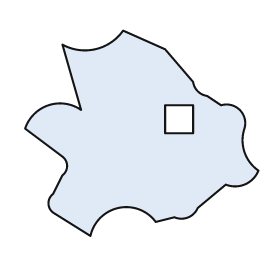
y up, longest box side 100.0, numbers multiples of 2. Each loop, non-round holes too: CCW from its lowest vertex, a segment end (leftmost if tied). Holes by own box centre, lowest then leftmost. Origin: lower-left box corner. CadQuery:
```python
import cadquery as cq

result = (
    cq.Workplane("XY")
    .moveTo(28.0, 0.0)
    .threePointArc((40.0, 12.0), (56.0, 6.0))
    .lineTo(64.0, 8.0)
    .threePointArc((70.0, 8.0), (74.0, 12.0))
    .lineTo(86.0, 22.0)
    .threePointArc((94.0, 22.0), (100.0, 28.0))
    .threePointArc((94.0, 36.0), (94.0, 46.0))
    .threePointArc((92.0, 54.0), (84.0, 56.0))
    .lineTo(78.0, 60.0)
    .threePointArc((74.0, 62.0), (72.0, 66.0))
    .lineTo(60.0, 80.0)
    .lineTo(42.0, 88.0)
    .threePointArc((30.0, 80.0), (16.0, 82.0))
    .lineTo(24.0, 54.0)
    .threePointArc((10.0, 56.0), (0.0, 46.0))
    .lineTo(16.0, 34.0)
    .threePointArc((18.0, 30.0), (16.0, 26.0))
    .lineTo(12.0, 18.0)
    .threePointArc((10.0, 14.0), (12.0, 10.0))
    .close()
    .moveTo(60.0, 44.0)
    .lineTo(72.0, 44.0)
    .lineTo(72.0, 56.0)
    .lineTo(60.0, 56.0)
    .close()
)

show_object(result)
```